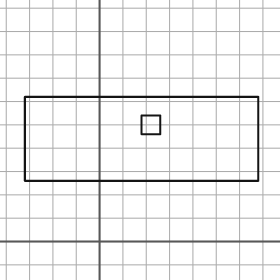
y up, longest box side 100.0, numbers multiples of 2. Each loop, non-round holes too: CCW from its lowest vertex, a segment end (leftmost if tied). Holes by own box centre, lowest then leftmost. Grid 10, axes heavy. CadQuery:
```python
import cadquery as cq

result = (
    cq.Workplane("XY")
    .moveTo(-32.0, 26.0)
    .lineTo(68.0, 26.0)
    .lineTo(68.0, 62.0)
    .lineTo(-32.0, 62.0)
    .close()
    .moveTo(18.0, 46.0)
    .lineTo(26.0, 46.0)
    .lineTo(26.0, 54.0)
    .lineTo(18.0, 54.0)
    .close()
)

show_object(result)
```